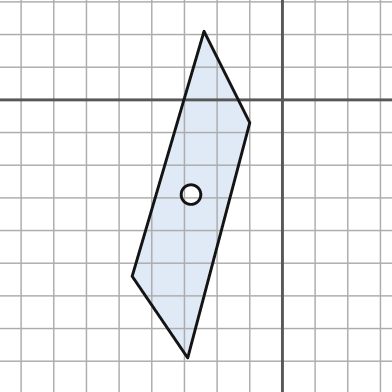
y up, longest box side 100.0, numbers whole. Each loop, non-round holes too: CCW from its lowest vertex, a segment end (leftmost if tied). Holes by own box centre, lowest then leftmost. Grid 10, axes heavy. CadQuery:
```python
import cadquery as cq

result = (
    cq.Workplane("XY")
    .moveTo(-29.0, -79.0)
    .lineTo(-10.0, -7.0)
    .lineTo(-24.0, 21.0)
    .lineTo(-46.0, -54.0)
    .close()
    .moveTo(-28.0, -29.0)
    .circle(3.0)
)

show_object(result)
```